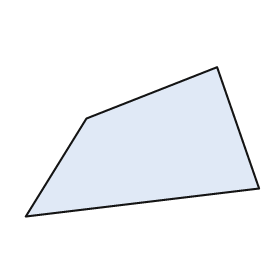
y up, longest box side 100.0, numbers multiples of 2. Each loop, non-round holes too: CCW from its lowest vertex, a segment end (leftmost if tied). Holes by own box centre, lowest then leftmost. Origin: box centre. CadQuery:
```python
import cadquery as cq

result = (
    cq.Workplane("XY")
    .moveTo(-50.0, -32.0)
    .lineTo(50.0, -20.0)
    .lineTo(32.0, 32.0)
    .lineTo(-24.0, 10.0)
    .close()
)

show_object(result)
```